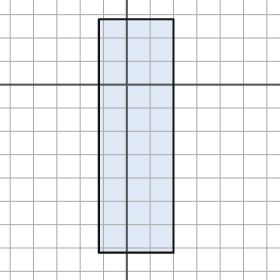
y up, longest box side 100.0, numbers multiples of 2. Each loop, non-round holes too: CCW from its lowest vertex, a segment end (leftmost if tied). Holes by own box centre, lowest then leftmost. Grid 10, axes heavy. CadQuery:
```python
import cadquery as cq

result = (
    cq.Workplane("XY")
    .moveTo(-12.0, -72.0)
    .lineTo(20.0, -72.0)
    .lineTo(20.0, 28.0)
    .lineTo(-12.0, 28.0)
    .close()
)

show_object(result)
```